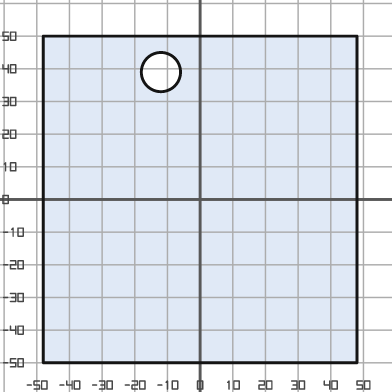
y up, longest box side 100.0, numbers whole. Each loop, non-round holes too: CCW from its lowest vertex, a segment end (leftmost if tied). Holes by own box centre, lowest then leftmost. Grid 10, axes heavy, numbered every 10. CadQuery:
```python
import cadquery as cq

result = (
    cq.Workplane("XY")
    .moveTo(-48.0, -50.0)
    .lineTo(48.0, -50.0)
    .lineTo(48.0, 50.0)
    .lineTo(-48.0, 50.0)
    .close()
    .moveTo(-12.0, 39.0)
    .circle(6.0)
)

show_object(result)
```